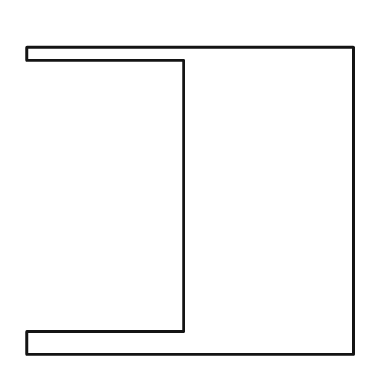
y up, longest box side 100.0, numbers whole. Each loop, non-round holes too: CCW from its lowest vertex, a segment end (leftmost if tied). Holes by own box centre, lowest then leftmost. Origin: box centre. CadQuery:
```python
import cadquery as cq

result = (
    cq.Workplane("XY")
    .moveTo(-50.0, -47.0)
    .lineTo(50.0, -47.0)
    .lineTo(50.0, 47.0)
    .lineTo(-50.0, 47.0)
    .lineTo(-50.0, 43.0)
    .lineTo(-2.0, 43.0)
    .lineTo(-2.0, -40.0)
    .lineTo(-50.0, -40.0)
    .close()
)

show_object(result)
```